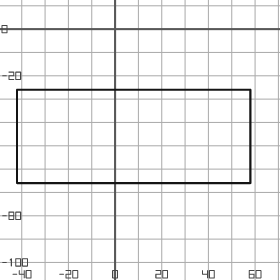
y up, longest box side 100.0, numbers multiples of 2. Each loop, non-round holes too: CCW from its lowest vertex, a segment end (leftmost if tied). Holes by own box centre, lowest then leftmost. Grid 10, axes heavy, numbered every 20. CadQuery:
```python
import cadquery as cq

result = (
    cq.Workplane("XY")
    .moveTo(-42.0, -66.0)
    .lineTo(58.0, -66.0)
    .lineTo(58.0, -26.0)
    .lineTo(-42.0, -26.0)
    .close()
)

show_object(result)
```